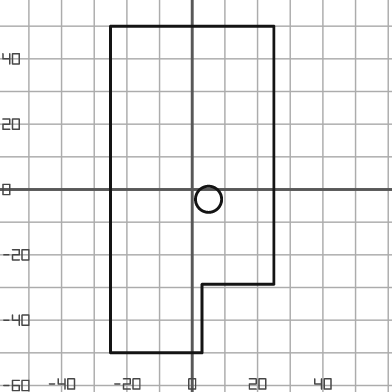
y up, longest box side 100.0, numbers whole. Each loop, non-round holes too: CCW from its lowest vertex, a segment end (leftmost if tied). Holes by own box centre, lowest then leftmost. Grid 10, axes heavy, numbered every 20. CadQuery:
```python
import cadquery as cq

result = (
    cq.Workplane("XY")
    .moveTo(-25.0, -50.0)
    .lineTo(3.0, -50.0)
    .lineTo(3.0, -29.0)
    .lineTo(25.0, -29.0)
    .lineTo(25.0, 50.0)
    .lineTo(-25.0, 50.0)
    .close()
    .moveTo(5.0, -3.0)
    .circle(4.0)
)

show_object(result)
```